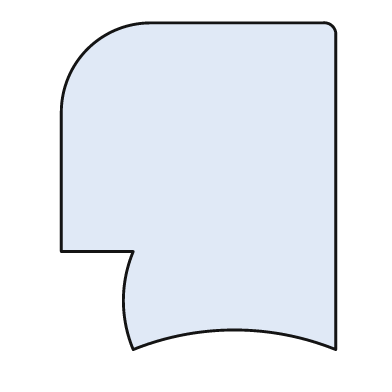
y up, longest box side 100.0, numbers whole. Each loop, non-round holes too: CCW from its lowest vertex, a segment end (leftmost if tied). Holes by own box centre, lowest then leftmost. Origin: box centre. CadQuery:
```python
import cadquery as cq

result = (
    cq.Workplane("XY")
    .moveTo(-20.0, -50.0)
    .threePointArc((11.0, -44.0), (42.0, -50.0))
    .lineTo(42.0, 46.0)
    .threePointArc((41.0, 49.0), (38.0, 50.0))
    .lineTo(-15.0, 50.0)
    .threePointArc((-34.0, 42.0), (-42.0, 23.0))
    .lineTo(-42.0, -20.0)
    .lineTo(-20.0, -20.0)
    .threePointArc((-23.0, -35.0), (-20.0, -50.0))
    .close()
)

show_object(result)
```